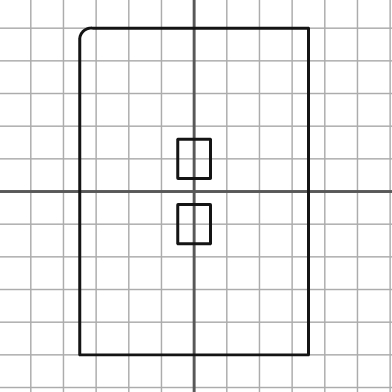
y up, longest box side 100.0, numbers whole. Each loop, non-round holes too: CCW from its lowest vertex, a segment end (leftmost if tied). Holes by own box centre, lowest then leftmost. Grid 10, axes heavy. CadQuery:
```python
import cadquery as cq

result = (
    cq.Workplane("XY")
    .moveTo(-35.0, -50.0)
    .lineTo(35.0, -50.0)
    .lineTo(35.0, 50.0)
    .lineTo(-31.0, 50.0)
    .threePointArc((-34.0, 49.0), (-35.0, 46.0))
    .close()
    .moveTo(-5.0, -16.0)
    .lineTo(5.0, -16.0)
    .lineTo(5.0, -4.0)
    .lineTo(-5.0, -4.0)
    .close()
    .moveTo(-5.0, 4.0)
    .lineTo(5.0, 4.0)
    .lineTo(5.0, 16.0)
    .lineTo(-5.0, 16.0)
    .close()
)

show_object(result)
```